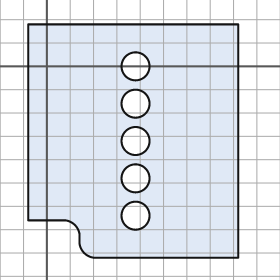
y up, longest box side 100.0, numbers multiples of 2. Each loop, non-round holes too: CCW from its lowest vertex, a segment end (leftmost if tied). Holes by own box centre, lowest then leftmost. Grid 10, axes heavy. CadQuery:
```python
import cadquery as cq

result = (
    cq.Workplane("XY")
    .moveTo(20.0, -82.0)
    .lineTo(82.0, -82.0)
    .lineTo(82.0, 18.0)
    .lineTo(-8.0, 18.0)
    .lineTo(-8.0, -66.0)
    .lineTo(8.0, -66.0)
    .threePointArc((12.0, -68.0), (14.0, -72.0))
    .lineTo(14.0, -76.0)
    .threePointArc((16.0, -80.0), (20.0, -82.0))
    .close()
    .moveTo(38.0, -64.0)
    .circle(6.0)
    .moveTo(38.0, -48.0)
    .circle(6.0)
    .moveTo(38.0, -32.0)
    .circle(6.0)
    .moveTo(38.0, -16.0)
    .circle(6.0)
    .moveTo(38.0, 0.0)
    .circle(6.0)
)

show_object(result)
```